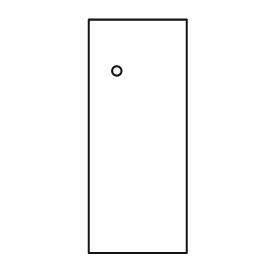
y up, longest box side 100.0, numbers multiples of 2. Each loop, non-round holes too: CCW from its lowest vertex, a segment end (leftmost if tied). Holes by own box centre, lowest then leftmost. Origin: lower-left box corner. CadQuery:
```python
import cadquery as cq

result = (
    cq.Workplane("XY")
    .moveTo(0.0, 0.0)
    .lineTo(42.0, 0.0)
    .lineTo(42.0, 100.0)
    .lineTo(0.0, 100.0)
    .close()
    .moveTo(12.0, 78.0)
    .circle(2.0)
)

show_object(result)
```